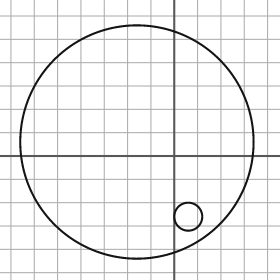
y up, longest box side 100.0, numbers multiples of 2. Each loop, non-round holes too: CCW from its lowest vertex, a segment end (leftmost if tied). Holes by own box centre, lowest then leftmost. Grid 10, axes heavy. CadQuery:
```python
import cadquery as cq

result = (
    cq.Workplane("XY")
    .moveTo(-16.0, 6.0)
    .circle(50.0)
    .moveTo(6.0, -26.0)
    .circle(6.0)
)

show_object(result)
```